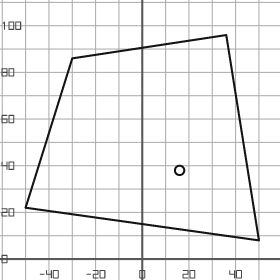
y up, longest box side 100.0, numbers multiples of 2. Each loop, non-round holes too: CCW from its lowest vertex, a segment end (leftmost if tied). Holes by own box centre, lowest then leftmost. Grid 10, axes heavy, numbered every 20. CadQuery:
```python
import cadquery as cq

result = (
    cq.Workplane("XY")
    .moveTo(50.0, 8.0)
    .lineTo(36.0, 96.0)
    .lineTo(-30.0, 86.0)
    .lineTo(-50.0, 22.0)
    .close()
    .moveTo(16.0, 38.0)
    .circle(2.0)
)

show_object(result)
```